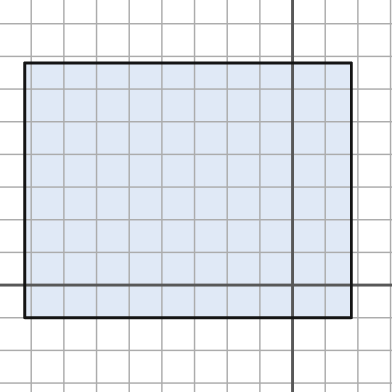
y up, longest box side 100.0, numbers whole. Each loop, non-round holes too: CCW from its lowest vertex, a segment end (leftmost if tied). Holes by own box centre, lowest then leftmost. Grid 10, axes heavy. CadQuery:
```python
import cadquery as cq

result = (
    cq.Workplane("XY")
    .moveTo(-82.0, -10.0)
    .lineTo(18.0, -10.0)
    .lineTo(18.0, 68.0)
    .lineTo(-82.0, 68.0)
    .close()
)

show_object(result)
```